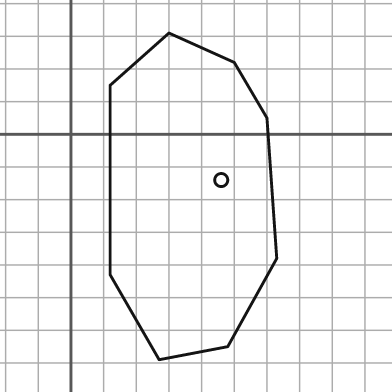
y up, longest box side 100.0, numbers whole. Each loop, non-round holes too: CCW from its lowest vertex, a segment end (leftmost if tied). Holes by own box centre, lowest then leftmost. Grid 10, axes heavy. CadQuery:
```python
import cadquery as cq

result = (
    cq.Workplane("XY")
    .moveTo(27.0, -69.0)
    .lineTo(48.0, -65.0)
    .lineTo(63.0, -38.0)
    .lineTo(60.0, 5.0)
    .lineTo(50.0, 22.0)
    .lineTo(30.0, 31.0)
    .lineTo(12.0, 15.0)
    .lineTo(12.0, -43.0)
    .close()
    .moveTo(46.0, -14.0)
    .circle(2.0)
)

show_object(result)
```